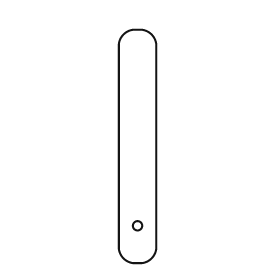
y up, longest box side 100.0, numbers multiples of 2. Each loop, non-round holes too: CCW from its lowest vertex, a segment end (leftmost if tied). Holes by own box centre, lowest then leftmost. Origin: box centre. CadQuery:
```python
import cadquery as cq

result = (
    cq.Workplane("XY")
    .moveTo(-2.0, -50.0)
    .lineTo(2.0, -50.0)
    .threePointArc((6.0, -48.0), (8.0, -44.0))
    .lineTo(8.0, 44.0)
    .threePointArc((6.0, 48.0), (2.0, 50.0))
    .lineTo(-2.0, 50.0)
    .threePointArc((-6.0, 48.0), (-8.0, 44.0))
    .lineTo(-8.0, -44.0)
    .threePointArc((-6.0, -48.0), (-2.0, -50.0))
    .close()
    .moveTo(0.0, -34.0)
    .circle(2.0)
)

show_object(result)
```